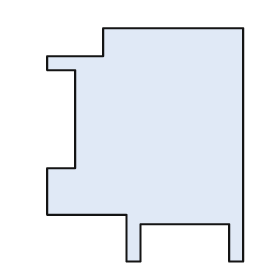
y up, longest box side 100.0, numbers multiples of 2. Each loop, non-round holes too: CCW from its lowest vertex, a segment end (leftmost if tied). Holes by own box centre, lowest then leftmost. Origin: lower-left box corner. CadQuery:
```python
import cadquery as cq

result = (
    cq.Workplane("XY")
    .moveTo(34.0, 0.0)
    .lineTo(40.0, 0.0)
    .lineTo(40.0, 16.0)
    .lineTo(78.0, 16.0)
    .lineTo(78.0, 0.0)
    .lineTo(84.0, 0.0)
    .lineTo(84.0, 100.0)
    .lineTo(24.0, 100.0)
    .lineTo(24.0, 88.0)
    .lineTo(0.0, 88.0)
    .lineTo(0.0, 82.0)
    .lineTo(12.0, 82.0)
    .lineTo(12.0, 40.0)
    .lineTo(0.0, 40.0)
    .lineTo(0.0, 20.0)
    .lineTo(34.0, 20.0)
    .close()
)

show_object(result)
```